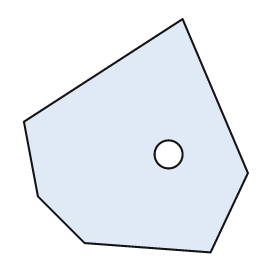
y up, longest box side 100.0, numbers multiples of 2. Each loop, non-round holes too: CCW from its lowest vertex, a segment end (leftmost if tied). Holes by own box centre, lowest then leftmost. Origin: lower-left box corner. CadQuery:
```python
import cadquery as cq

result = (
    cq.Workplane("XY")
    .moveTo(80.0, 0.0)
    .lineTo(96.0, 34.0)
    .lineTo(68.0, 100.0)
    .lineTo(0.0, 56.0)
    .lineTo(6.0, 24.0)
    .lineTo(26.0, 4.0)
    .close()
    .moveTo(62.0, 42.0)
    .circle(6.0)
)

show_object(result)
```